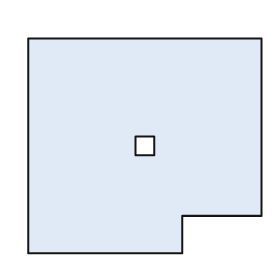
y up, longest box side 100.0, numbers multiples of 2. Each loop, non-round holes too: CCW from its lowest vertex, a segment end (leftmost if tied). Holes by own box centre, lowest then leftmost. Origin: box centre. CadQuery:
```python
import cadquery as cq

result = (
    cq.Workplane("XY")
    .moveTo(-50.0, -46.0)
    .lineTo(16.0, -46.0)
    .lineTo(16.0, -30.0)
    .lineTo(50.0, -30.0)
    .lineTo(50.0, 46.0)
    .lineTo(-50.0, 46.0)
    .close()
    .moveTo(-4.0, -4.0)
    .lineTo(4.0, -4.0)
    .lineTo(4.0, 4.0)
    .lineTo(-4.0, 4.0)
    .close()
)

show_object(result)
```